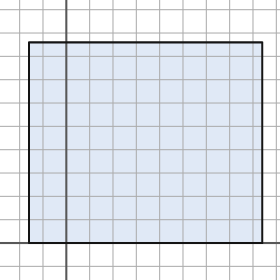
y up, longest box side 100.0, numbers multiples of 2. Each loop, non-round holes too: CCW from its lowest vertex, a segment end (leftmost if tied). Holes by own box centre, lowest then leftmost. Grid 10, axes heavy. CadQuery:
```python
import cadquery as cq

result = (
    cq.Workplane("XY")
    .moveTo(-16.0, 0.0)
    .lineTo(84.0, 0.0)
    .lineTo(84.0, 86.0)
    .lineTo(-16.0, 86.0)
    .close()
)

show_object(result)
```